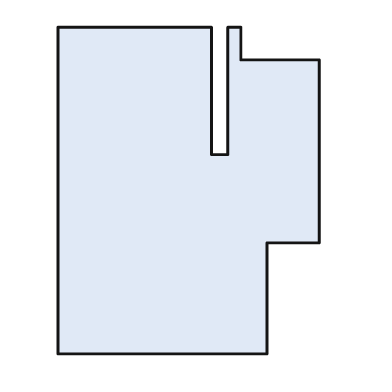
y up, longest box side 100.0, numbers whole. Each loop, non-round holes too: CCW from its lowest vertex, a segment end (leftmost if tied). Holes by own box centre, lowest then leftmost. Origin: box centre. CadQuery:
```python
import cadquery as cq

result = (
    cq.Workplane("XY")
    .moveTo(-40.0, -50.0)
    .lineTo(24.0, -50.0)
    .lineTo(24.0, -16.0)
    .lineTo(40.0, -16.0)
    .lineTo(40.0, 40.0)
    .lineTo(16.0, 40.0)
    .lineTo(16.0, 50.0)
    .lineTo(12.0, 50.0)
    .lineTo(12.0, 11.0)
    .lineTo(7.0, 11.0)
    .lineTo(7.0, 50.0)
    .lineTo(-40.0, 50.0)
    .close()
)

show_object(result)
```